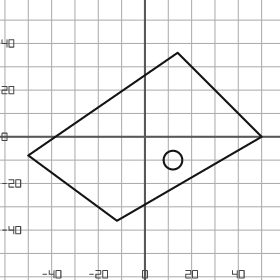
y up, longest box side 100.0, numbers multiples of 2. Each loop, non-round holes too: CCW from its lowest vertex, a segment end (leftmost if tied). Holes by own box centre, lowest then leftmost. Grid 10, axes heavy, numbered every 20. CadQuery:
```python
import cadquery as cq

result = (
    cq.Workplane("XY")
    .moveTo(-12.0, -36.0)
    .lineTo(50.0, 0.0)
    .lineTo(14.0, 36.0)
    .lineTo(-50.0, -8.0)
    .close()
    .moveTo(12.0, -10.0)
    .circle(4.0)
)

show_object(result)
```